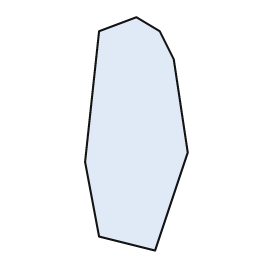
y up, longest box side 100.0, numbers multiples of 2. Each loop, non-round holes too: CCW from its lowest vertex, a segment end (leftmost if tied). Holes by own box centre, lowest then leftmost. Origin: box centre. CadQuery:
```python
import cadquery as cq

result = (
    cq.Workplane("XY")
    .moveTo(8.0, -50.0)
    .lineTo(22.0, -8.0)
    .lineTo(16.0, 32.0)
    .lineTo(10.0, 44.0)
    .lineTo(0.0, 50.0)
    .lineTo(-16.0, 44.0)
    .lineTo(-22.0, -12.0)
    .lineTo(-16.0, -44.0)
    .close()
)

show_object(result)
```